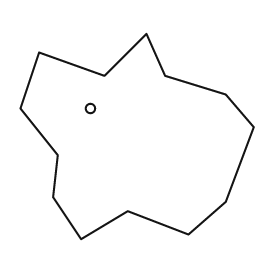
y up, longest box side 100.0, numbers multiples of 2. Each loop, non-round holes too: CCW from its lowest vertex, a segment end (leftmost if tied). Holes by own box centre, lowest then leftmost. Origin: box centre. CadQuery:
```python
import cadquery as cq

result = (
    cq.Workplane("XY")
    .moveTo(-24.0, -44.0)
    .lineTo(-4.0, -32.0)
    .lineTo(22.0, -42.0)
    .lineTo(38.0, -28.0)
    .lineTo(50.0, 4.0)
    .lineTo(38.0, 18.0)
    .lineTo(12.0, 26.0)
    .lineTo(4.0, 44.0)
    .lineTo(-14.0, 26.0)
    .lineTo(-42.0, 36.0)
    .lineTo(-50.0, 12.0)
    .lineTo(-34.0, -8.0)
    .lineTo(-36.0, -26.0)
    .close()
    .moveTo(-20.0, 12.0)
    .circle(2.0)
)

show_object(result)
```